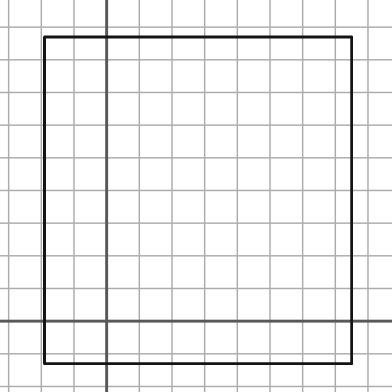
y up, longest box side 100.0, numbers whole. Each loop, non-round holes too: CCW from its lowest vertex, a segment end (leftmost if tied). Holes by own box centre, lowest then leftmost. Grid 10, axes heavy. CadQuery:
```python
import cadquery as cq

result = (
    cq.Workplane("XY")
    .moveTo(-19.0, -13.0)
    .lineTo(75.0, -13.0)
    .lineTo(75.0, 87.0)
    .lineTo(-19.0, 87.0)
    .close()
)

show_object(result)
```